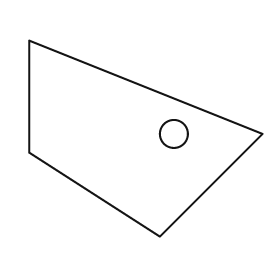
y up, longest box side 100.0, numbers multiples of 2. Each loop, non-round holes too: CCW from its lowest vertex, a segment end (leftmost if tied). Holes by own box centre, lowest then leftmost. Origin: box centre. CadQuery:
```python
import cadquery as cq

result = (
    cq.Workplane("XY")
    .moveTo(6.0, -42.0)
    .lineTo(50.0, 2.0)
    .lineTo(-50.0, 42.0)
    .lineTo(-50.0, -6.0)
    .close()
    .moveTo(12.0, 2.0)
    .circle(6.0)
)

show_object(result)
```